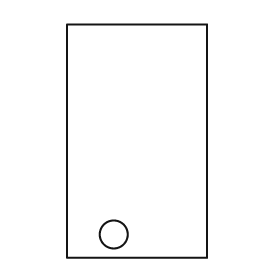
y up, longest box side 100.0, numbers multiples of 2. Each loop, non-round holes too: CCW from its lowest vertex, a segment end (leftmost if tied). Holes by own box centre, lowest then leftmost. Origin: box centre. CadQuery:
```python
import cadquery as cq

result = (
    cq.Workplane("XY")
    .moveTo(-30.0, -50.0)
    .lineTo(30.0, -50.0)
    .lineTo(30.0, 50.0)
    .lineTo(-30.0, 50.0)
    .close()
    .moveTo(-10.0, -40.0)
    .circle(6.0)
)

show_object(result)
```